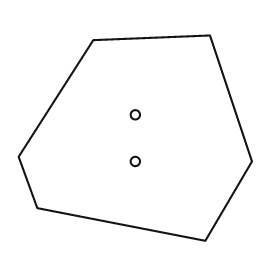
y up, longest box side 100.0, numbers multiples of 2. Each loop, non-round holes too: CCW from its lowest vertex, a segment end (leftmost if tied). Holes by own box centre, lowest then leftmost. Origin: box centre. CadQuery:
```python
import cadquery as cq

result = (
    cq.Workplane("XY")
    .moveTo(30.0, -44.0)
    .lineTo(50.0, -10.0)
    .lineTo(32.0, 44.0)
    .lineTo(-18.0, 42.0)
    .lineTo(-50.0, -8.0)
    .lineTo(-42.0, -30.0)
    .close()
    .moveTo(0.0, -10.0)
    .circle(2.0)
    .moveTo(0.0, 10.0)
    .circle(2.0)
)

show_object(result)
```